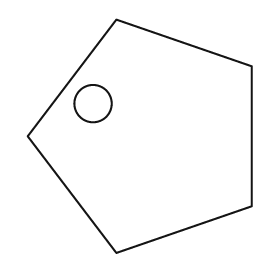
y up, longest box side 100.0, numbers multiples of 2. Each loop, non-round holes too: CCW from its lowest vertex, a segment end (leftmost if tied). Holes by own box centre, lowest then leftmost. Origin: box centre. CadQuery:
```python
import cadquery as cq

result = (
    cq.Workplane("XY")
    .moveTo(-10.0, -50.0)
    .lineTo(48.0, -30.0)
    .lineTo(48.0, 30.0)
    .lineTo(-10.0, 50.0)
    .lineTo(-48.0, 0.0)
    .close()
    .moveTo(-20.0, 14.0)
    .circle(8.0)
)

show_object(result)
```